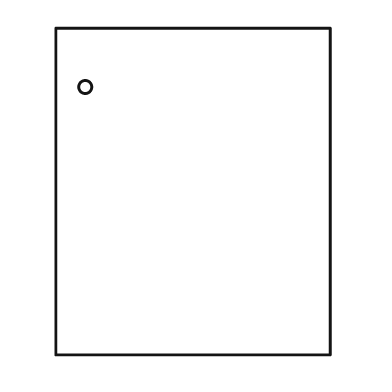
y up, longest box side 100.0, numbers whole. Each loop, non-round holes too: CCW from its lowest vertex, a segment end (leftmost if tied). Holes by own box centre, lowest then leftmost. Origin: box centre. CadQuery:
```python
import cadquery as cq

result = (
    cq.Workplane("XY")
    .moveTo(-42.0, -50.0)
    .lineTo(42.0, -50.0)
    .lineTo(42.0, 50.0)
    .lineTo(-42.0, 50.0)
    .close()
    .moveTo(-33.0, 32.0)
    .circle(2.0)
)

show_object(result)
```